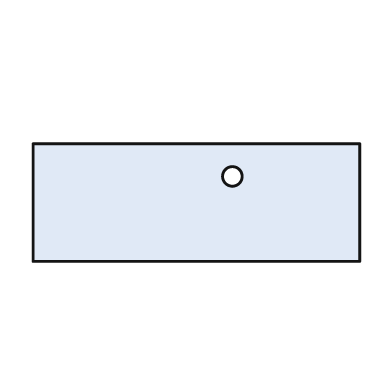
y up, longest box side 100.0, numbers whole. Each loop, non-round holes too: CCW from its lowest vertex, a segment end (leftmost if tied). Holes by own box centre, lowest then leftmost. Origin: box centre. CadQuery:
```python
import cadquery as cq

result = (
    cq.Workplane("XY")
    .moveTo(-50.0, -18.0)
    .lineTo(50.0, -18.0)
    .lineTo(50.0, 18.0)
    .lineTo(-50.0, 18.0)
    .close()
    .moveTo(11.0, 8.0)
    .circle(3.0)
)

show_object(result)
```